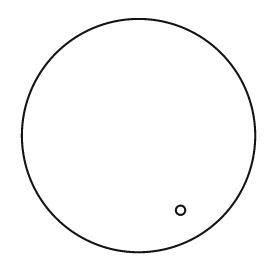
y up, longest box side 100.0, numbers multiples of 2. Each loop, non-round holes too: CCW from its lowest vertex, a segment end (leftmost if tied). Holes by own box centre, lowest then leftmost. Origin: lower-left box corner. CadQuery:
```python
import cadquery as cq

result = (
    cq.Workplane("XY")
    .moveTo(50.0, 50.0)
    .circle(50.0)
    .moveTo(68.0, 18.0)
    .circle(2.0)
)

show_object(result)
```